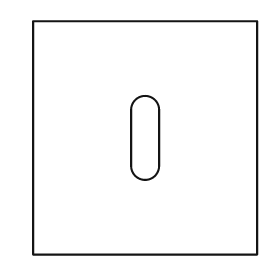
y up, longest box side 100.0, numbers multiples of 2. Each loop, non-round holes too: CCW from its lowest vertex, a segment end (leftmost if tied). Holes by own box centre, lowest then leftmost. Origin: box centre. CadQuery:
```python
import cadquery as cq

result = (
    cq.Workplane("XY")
    .moveTo(-48.0, -50.0)
    .lineTo(48.0, -50.0)
    .lineTo(48.0, 50.0)
    .lineTo(-48.0, 50.0)
    .close()
    .moveTo(-6.0, -12.0)
    .threePointArc((0.0, -18.0), (6.0, -12.0))
    .lineTo(6.0, 12.0)
    .threePointArc((0.0, 18.0), (-6.0, 12.0))
    .close()
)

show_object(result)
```